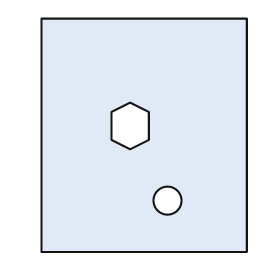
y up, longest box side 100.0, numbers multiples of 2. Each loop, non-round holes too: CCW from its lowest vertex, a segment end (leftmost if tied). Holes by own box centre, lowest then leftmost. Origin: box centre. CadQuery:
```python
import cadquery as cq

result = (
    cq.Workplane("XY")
    .moveTo(-44.0, -50.0)
    .lineTo(44.0, -50.0)
    .lineTo(44.0, 50.0)
    .lineTo(-44.0, 50.0)
    .close()
    .moveTo(10.0, -28.0)
    .circle(6.0)
    .moveTo(-6.0, -6.0)
    .lineTo(2.0, -2.0)
    .lineTo(2.0, 10.0)
    .lineTo(-6.0, 14.0)
    .lineTo(-14.0, 10.0)
    .lineTo(-14.0, -2.0)
    .close()
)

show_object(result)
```